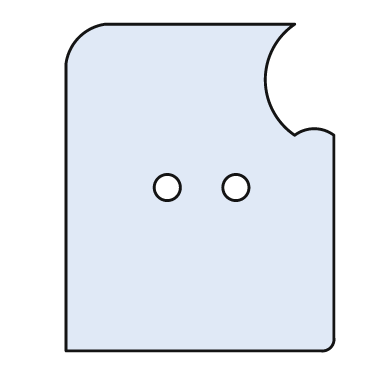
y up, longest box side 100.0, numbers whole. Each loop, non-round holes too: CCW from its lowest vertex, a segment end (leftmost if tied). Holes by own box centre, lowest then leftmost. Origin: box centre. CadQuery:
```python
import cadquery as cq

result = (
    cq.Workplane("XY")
    .moveTo(-41.0, -50.0)
    .lineTo(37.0, -50.0)
    .threePointArc((40.0, -49.0), (41.0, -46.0))
    .lineTo(41.0, 16.0)
    .threePointArc((35.0, 18.0), (29.0, 16.0))
    .threePointArc((20.0, 33.0), (29.0, 50.0))
    .lineTo(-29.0, 50.0)
    .threePointArc((-37.0, 46.0), (-41.0, 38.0))
    .close()
    .moveTo(-10.0, 0.0)
    .circle(4.0)
    .moveTo(11.0, 0.0)
    .circle(4.0)
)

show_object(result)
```